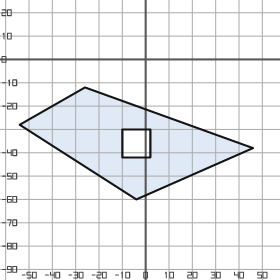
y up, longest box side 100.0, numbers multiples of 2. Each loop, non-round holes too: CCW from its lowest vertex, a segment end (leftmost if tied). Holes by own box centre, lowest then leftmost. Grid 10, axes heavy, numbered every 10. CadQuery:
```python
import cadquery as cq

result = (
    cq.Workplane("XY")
    .moveTo(-4.0, -60.0)
    .lineTo(46.0, -38.0)
    .lineTo(-26.0, -12.0)
    .lineTo(-54.0, -28.0)
    .close()
    .moveTo(-10.0, -42.0)
    .lineTo(2.0, -42.0)
    .lineTo(2.0, -30.0)
    .lineTo(-10.0, -30.0)
    .close()
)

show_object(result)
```